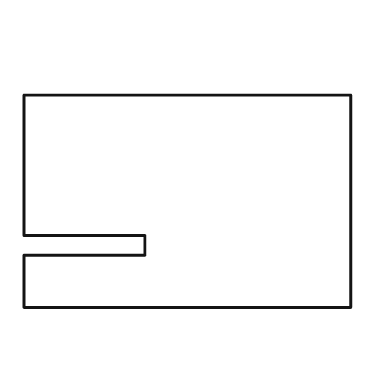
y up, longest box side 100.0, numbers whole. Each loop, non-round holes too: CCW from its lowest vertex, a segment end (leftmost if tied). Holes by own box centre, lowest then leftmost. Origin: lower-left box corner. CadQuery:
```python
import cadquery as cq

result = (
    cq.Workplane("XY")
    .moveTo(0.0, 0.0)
    .lineTo(100.0, 0.0)
    .lineTo(100.0, 65.0)
    .lineTo(0.0, 65.0)
    .lineTo(0.0, 22.0)
    .lineTo(37.0, 22.0)
    .lineTo(37.0, 16.0)
    .lineTo(0.0, 16.0)
    .close()
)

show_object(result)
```